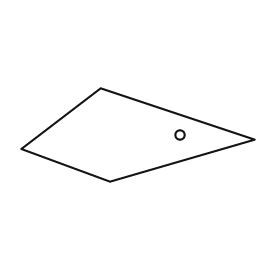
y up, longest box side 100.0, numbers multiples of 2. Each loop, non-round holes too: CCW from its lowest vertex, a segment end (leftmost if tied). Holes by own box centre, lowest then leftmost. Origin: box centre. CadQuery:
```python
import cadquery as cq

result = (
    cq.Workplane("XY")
    .moveTo(-12.0, -20.0)
    .lineTo(50.0, -2.0)
    .lineTo(-16.0, 20.0)
    .lineTo(-50.0, -6.0)
    .close()
    .moveTo(18.0, 0.0)
    .circle(2.0)
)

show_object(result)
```